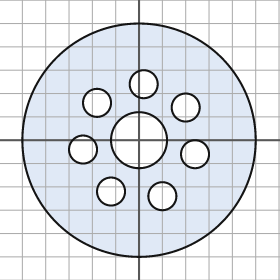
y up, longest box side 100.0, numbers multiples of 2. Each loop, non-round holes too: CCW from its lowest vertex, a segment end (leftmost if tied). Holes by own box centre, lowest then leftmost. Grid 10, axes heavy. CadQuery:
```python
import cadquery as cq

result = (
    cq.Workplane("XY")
    .moveTo(0.0, 0.0)
    .circle(50.0)
    .moveTo(10.0, -24.0)
    .circle(6.0)
    .moveTo(-12.0, -22.0)
    .circle(6.0)
    .moveTo(24.0, -6.0)
    .circle(6.0)
    .moveTo(-24.0, -4.0)
    .circle(6.0)
    .moveTo(0.0, 0.0)
    .circle(12.0)
    .moveTo(20.0, 14.0)
    .circle(6.0)
    .moveTo(-18.0, 16.0)
    .circle(6.0)
    .moveTo(2.0, 24.0)
    .circle(6.0)
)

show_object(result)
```